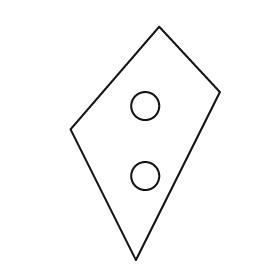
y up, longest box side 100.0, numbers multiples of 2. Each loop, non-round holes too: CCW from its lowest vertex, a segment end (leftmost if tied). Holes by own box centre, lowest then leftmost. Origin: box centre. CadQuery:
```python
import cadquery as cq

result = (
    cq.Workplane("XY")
    .moveTo(-4.0, -50.0)
    .lineTo(32.0, 22.0)
    .lineTo(6.0, 50.0)
    .lineTo(-32.0, 6.0)
    .close()
    .moveTo(0.0, -14.0)
    .circle(6.0)
    .moveTo(0.0, 16.0)
    .circle(6.0)
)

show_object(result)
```